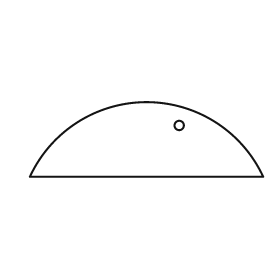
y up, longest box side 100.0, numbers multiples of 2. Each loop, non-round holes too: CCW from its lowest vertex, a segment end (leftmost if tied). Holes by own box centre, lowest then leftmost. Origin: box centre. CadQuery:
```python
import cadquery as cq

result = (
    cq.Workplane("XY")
    .moveTo(-50.0, -16.0)
    .lineTo(50.0, -16.0)
    .threePointArc((0.0, 16.0), (-50.0, -16.0))
    .close()
    .moveTo(14.0, 6.0)
    .circle(2.0)
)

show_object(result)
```